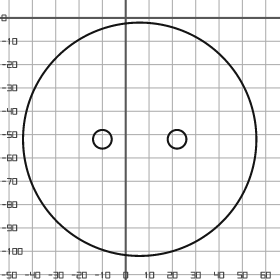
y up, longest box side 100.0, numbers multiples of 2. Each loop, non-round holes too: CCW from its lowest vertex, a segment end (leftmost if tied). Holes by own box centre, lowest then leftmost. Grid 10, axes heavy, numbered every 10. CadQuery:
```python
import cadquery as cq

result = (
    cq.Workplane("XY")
    .moveTo(6.0, -52.0)
    .circle(50.0)
    .moveTo(-10.0, -52.0)
    .circle(4.0)
    .moveTo(22.0, -52.0)
    .circle(4.0)
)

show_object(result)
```